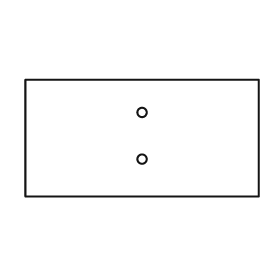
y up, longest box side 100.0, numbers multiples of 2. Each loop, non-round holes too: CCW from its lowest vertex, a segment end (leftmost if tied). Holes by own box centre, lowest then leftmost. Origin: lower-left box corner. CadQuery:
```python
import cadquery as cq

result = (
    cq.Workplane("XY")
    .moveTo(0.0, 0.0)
    .lineTo(100.0, 0.0)
    .lineTo(100.0, 50.0)
    .lineTo(0.0, 50.0)
    .close()
    .moveTo(50.0, 16.0)
    .circle(2.0)
    .moveTo(50.0, 36.0)
    .circle(2.0)
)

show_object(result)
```